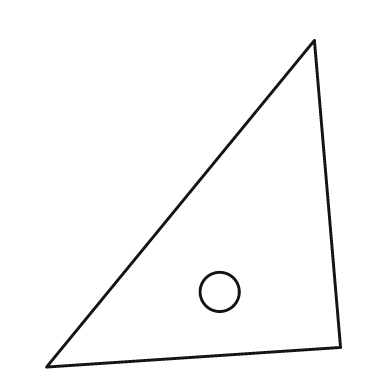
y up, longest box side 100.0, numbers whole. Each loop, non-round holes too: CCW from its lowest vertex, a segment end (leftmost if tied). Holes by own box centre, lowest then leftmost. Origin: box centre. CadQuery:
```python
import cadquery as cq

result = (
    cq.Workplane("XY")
    .moveTo(-45.0, -50.0)
    .lineTo(45.0, -44.0)
    .lineTo(37.0, 50.0)
    .close()
    .moveTo(8.0, -27.0)
    .circle(6.0)
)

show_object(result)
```